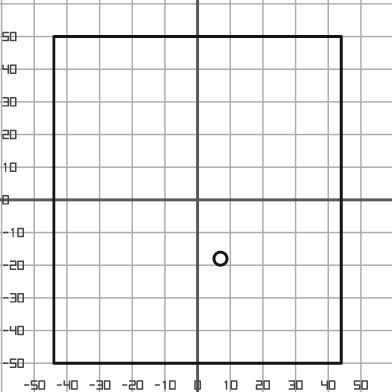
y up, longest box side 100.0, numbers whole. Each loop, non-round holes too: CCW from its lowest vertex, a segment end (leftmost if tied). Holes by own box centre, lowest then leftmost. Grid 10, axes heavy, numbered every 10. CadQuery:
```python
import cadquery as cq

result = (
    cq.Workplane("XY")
    .moveTo(-44.0, -50.0)
    .lineTo(44.0, -50.0)
    .lineTo(44.0, 50.0)
    .lineTo(-44.0, 50.0)
    .close()
    .moveTo(7.0, -18.0)
    .circle(2.0)
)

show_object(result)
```